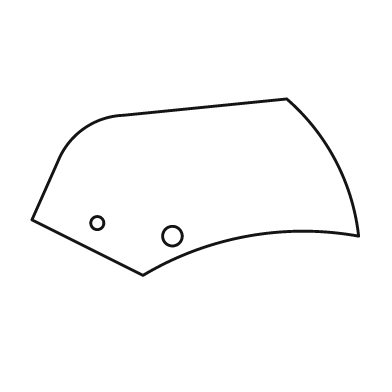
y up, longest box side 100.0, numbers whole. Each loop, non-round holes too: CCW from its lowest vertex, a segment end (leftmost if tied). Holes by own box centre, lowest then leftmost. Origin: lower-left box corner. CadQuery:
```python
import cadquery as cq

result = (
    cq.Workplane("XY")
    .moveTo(34.0, 0.0)
    .threePointArc((66.0, 12.0), (100.0, 12.0))
    .threePointArc((93.0, 35.0), (78.0, 54.0))
    .lineTo(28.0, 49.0)
    .threePointArc((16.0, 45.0), (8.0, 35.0))
    .lineTo(0.0, 17.0)
    .close()
    .moveTo(43.0, 12.0)
    .circle(3.0)
    .moveTo(20.0, 16.0)
    .circle(2.0)
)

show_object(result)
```